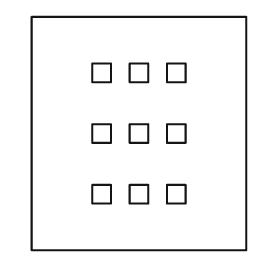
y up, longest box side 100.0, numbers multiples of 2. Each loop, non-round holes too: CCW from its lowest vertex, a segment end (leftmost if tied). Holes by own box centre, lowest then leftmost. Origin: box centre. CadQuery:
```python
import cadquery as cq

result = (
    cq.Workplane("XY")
    .moveTo(-46.0, -50.0)
    .lineTo(46.0, -50.0)
    .lineTo(46.0, 50.0)
    .lineTo(-46.0, 50.0)
    .close()
    .moveTo(-20.0, -30.0)
    .lineTo(-12.0, -30.0)
    .lineTo(-12.0, -22.0)
    .lineTo(-20.0, -22.0)
    .close()
    .moveTo(-4.0, -30.0)
    .lineTo(4.0, -30.0)
    .lineTo(4.0, -22.0)
    .lineTo(-4.0, -22.0)
    .close()
    .moveTo(12.0, -30.0)
    .lineTo(20.0, -30.0)
    .lineTo(20.0, -22.0)
    .lineTo(12.0, -22.0)
    .close()
    .moveTo(-20.0, -4.0)
    .lineTo(-12.0, -4.0)
    .lineTo(-12.0, 4.0)
    .lineTo(-20.0, 4.0)
    .close()
    .moveTo(-4.0, -4.0)
    .lineTo(4.0, -4.0)
    .lineTo(4.0, 4.0)
    .lineTo(-4.0, 4.0)
    .close()
    .moveTo(12.0, -4.0)
    .lineTo(20.0, -4.0)
    .lineTo(20.0, 4.0)
    .lineTo(12.0, 4.0)
    .close()
    .moveTo(-20.0, 22.0)
    .lineTo(-12.0, 22.0)
    .lineTo(-12.0, 30.0)
    .lineTo(-20.0, 30.0)
    .close()
    .moveTo(-4.0, 22.0)
    .lineTo(4.0, 22.0)
    .lineTo(4.0, 30.0)
    .lineTo(-4.0, 30.0)
    .close()
    .moveTo(12.0, 22.0)
    .lineTo(20.0, 22.0)
    .lineTo(20.0, 30.0)
    .lineTo(12.0, 30.0)
    .close()
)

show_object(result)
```